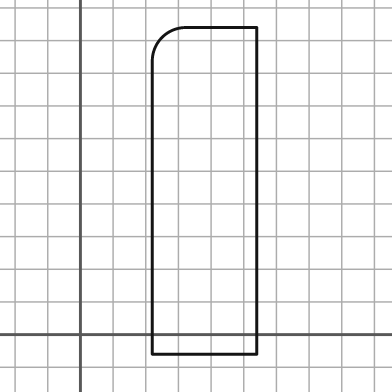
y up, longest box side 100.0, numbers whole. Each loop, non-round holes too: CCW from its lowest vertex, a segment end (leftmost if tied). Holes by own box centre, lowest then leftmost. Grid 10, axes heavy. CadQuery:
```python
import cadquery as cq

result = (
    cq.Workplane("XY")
    .moveTo(22.0, -6.0)
    .lineTo(54.0, -6.0)
    .lineTo(54.0, 94.0)
    .lineTo(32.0, 94.0)
    .threePointArc((25.0, 91.0), (22.0, 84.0))
    .close()
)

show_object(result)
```